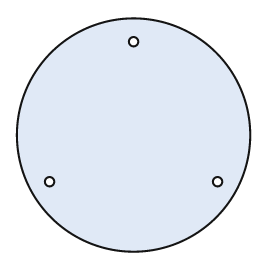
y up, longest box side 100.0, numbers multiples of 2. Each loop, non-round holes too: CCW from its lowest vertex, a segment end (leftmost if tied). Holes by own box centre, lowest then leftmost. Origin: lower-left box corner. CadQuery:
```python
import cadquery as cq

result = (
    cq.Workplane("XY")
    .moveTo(50.0, 50.0)
    .circle(50.0)
    .moveTo(14.0, 30.0)
    .circle(2.0)
    .moveTo(86.0, 30.0)
    .circle(2.0)
    .moveTo(50.0, 90.0)
    .circle(2.0)
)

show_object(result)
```